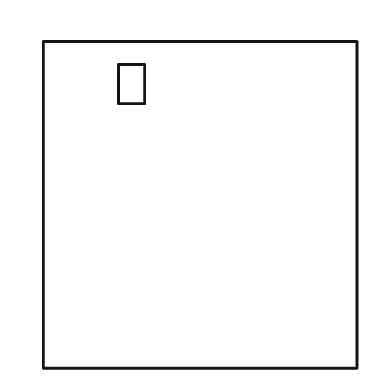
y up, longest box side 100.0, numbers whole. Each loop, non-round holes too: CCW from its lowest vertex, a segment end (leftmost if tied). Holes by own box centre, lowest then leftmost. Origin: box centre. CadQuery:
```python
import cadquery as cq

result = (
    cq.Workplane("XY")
    .moveTo(-48.0, -50.0)
    .lineTo(48.0, -50.0)
    .lineTo(48.0, 50.0)
    .lineTo(-48.0, 50.0)
    .close()
    .moveTo(-25.0, 31.0)
    .lineTo(-17.0, 31.0)
    .lineTo(-17.0, 43.0)
    .lineTo(-25.0, 43.0)
    .close()
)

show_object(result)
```